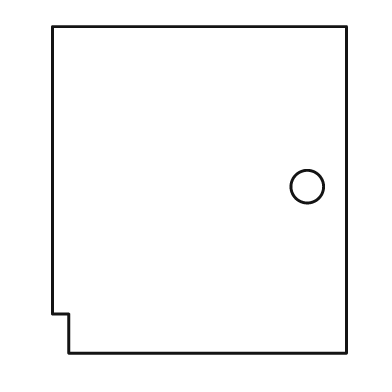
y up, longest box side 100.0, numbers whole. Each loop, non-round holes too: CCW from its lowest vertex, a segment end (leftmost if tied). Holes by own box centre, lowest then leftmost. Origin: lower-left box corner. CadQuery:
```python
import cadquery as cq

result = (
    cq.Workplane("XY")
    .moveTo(5.0, 0.0)
    .lineTo(90.0, 0.0)
    .lineTo(90.0, 100.0)
    .lineTo(0.0, 100.0)
    .lineTo(0.0, 12.0)
    .lineTo(5.0, 12.0)
    .close()
    .moveTo(78.0, 51.0)
    .circle(5.0)
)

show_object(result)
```